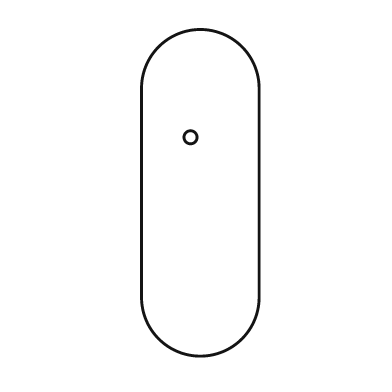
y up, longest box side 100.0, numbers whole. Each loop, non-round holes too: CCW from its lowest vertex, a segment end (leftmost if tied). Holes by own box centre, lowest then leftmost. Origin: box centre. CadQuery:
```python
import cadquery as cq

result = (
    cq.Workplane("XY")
    .moveTo(-18.0, -32.0)
    .threePointArc((0.0, -50.0), (18.0, -32.0))
    .lineTo(18.0, 32.0)
    .threePointArc((0.0, 50.0), (-18.0, 32.0))
    .close()
    .moveTo(-3.0, 17.0)
    .circle(2.0)
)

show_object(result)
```